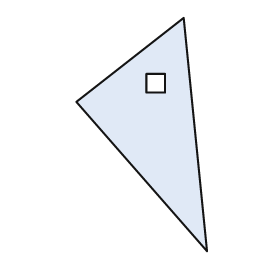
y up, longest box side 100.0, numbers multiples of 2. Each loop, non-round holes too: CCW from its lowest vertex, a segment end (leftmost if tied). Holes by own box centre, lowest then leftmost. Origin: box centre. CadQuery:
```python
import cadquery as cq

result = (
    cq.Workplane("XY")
    .moveTo(28.0, -50.0)
    .lineTo(18.0, 50.0)
    .lineTo(-28.0, 14.0)
    .close()
    .moveTo(2.0, 18.0)
    .lineTo(10.0, 18.0)
    .lineTo(10.0, 26.0)
    .lineTo(2.0, 26.0)
    .close()
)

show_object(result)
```